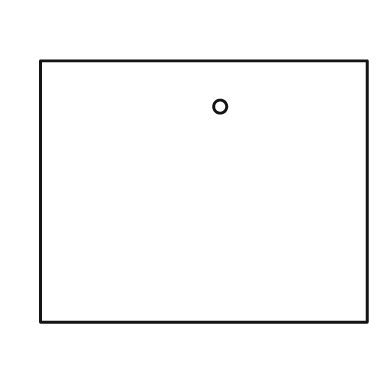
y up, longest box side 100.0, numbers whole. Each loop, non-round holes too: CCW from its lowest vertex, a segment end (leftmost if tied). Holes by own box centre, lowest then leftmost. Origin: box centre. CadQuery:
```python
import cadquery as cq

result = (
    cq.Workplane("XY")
    .moveTo(-50.0, -40.0)
    .lineTo(50.0, -40.0)
    .lineTo(50.0, 40.0)
    .lineTo(-50.0, 40.0)
    .close()
    .moveTo(5.0, 26.0)
    .circle(2.0)
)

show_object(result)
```